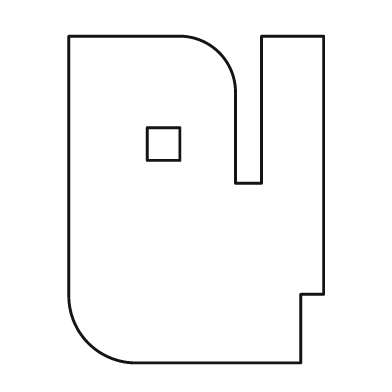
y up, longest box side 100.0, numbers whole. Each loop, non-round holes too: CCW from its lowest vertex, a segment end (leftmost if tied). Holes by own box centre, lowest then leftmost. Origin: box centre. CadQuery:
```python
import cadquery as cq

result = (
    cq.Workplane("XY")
    .moveTo(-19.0, -50.0)
    .lineTo(32.0, -50.0)
    .lineTo(32.0, -29.0)
    .lineTo(39.0, -29.0)
    .lineTo(39.0, 50.0)
    .lineTo(20.0, 50.0)
    .lineTo(20.0, 5.0)
    .lineTo(12.0, 5.0)
    .lineTo(12.0, 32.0)
    .threePointArc((7.0, 45.0), (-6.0, 50.0))
    .lineTo(-39.0, 50.0)
    .lineTo(-39.0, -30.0)
    .threePointArc((-33.0, -44.0), (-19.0, -50.0))
    .close()
    .moveTo(-15.0, 12.0)
    .lineTo(-5.0, 12.0)
    .lineTo(-5.0, 22.0)
    .lineTo(-15.0, 22.0)
    .close()
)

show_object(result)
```